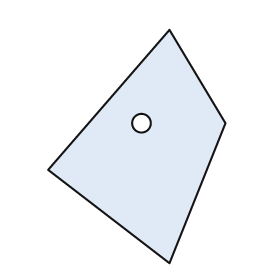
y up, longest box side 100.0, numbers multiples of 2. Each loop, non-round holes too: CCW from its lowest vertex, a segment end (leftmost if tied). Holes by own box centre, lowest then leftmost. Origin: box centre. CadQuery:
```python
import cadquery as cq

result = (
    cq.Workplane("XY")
    .moveTo(14.0, -50.0)
    .lineTo(38.0, 10.0)
    .lineTo(14.0, 50.0)
    .lineTo(-38.0, -10.0)
    .close()
    .moveTo(2.0, 10.0)
    .circle(4.0)
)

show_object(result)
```